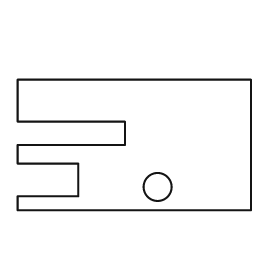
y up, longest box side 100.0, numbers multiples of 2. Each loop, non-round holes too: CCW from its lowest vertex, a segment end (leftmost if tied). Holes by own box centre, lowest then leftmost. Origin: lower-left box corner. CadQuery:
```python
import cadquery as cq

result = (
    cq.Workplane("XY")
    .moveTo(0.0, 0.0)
    .lineTo(100.0, 0.0)
    .lineTo(100.0, 56.0)
    .lineTo(0.0, 56.0)
    .lineTo(0.0, 38.0)
    .lineTo(46.0, 38.0)
    .lineTo(46.0, 28.0)
    .lineTo(0.0, 28.0)
    .lineTo(0.0, 20.0)
    .lineTo(26.0, 20.0)
    .lineTo(26.0, 6.0)
    .lineTo(0.0, 6.0)
    .close()
    .moveTo(60.0, 10.0)
    .circle(6.0)
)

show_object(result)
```